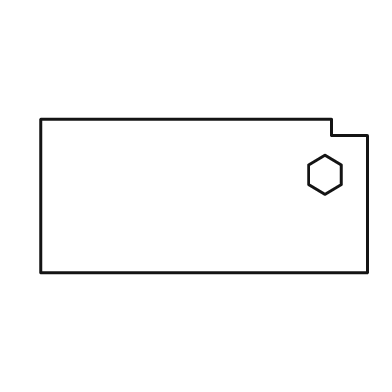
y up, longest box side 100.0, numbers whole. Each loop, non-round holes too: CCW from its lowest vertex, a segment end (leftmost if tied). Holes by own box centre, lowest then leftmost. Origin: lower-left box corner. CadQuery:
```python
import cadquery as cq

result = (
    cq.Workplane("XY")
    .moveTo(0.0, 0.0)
    .lineTo(100.0, 0.0)
    .lineTo(100.0, 42.0)
    .lineTo(89.0, 42.0)
    .lineTo(89.0, 47.0)
    .lineTo(0.0, 47.0)
    .close()
    .moveTo(87.0, 24.0)
    .lineTo(92.0, 27.0)
    .lineTo(92.0, 33.0)
    .lineTo(87.0, 36.0)
    .lineTo(82.0, 33.0)
    .lineTo(82.0, 27.0)
    .close()
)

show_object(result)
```